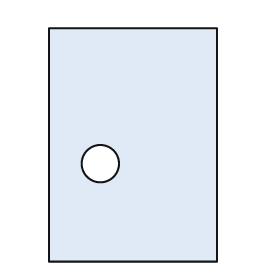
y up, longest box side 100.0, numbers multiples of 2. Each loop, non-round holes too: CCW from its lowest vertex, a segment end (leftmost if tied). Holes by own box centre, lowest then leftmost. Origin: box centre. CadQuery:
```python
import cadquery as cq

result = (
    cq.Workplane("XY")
    .moveTo(-36.0, -50.0)
    .lineTo(36.0, -50.0)
    .lineTo(36.0, 50.0)
    .lineTo(-36.0, 50.0)
    .close()
    .moveTo(-14.0, -8.0)
    .circle(8.0)
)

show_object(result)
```